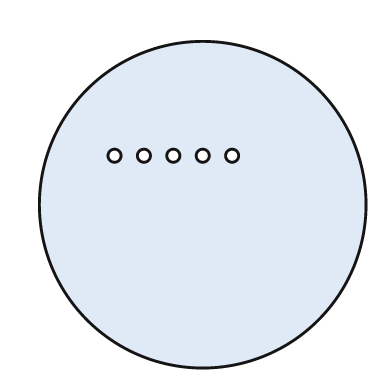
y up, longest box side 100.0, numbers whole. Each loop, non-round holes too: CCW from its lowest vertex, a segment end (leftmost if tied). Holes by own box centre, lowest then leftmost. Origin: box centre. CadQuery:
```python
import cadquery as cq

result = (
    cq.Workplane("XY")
    .moveTo(0.0, 0.0)
    .circle(50.0)
    .moveTo(-27.0, 15.0)
    .circle(2.0)
    .moveTo(-18.0, 15.0)
    .circle(2.0)
    .moveTo(-9.0, 15.0)
    .circle(2.0)
    .moveTo(0.0, 15.0)
    .circle(2.0)
    .moveTo(9.0, 15.0)
    .circle(2.0)
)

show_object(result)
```